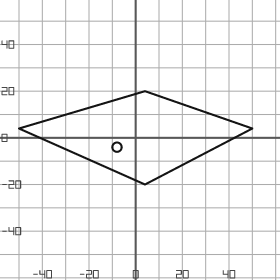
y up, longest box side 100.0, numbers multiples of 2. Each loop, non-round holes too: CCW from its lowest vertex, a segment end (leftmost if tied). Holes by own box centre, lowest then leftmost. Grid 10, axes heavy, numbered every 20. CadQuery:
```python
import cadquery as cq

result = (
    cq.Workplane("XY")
    .moveTo(4.0, -20.0)
    .lineTo(50.0, 4.0)
    .lineTo(4.0, 20.0)
    .lineTo(-50.0, 4.0)
    .close()
    .moveTo(-8.0, -4.0)
    .circle(2.0)
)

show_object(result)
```